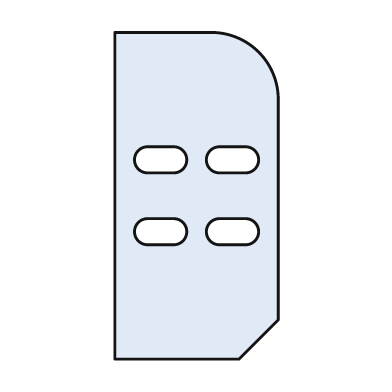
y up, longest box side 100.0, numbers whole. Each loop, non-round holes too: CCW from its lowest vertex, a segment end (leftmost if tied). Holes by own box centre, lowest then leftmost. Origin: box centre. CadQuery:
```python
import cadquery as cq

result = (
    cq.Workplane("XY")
    .moveTo(-25.0, -50.0)
    .lineTo(13.0, -50.0)
    .lineTo(25.0, -38.0)
    .lineTo(25.0, 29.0)
    .threePointArc((19.0, 44.0), (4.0, 50.0))
    .lineTo(-25.0, 50.0)
    .close()
    .moveTo(-15.0, -15.0)
    .lineTo(-7.0, -15.0)
    .threePointArc((-3.0, -11.0), (-7.0, -7.0))
    .lineTo(-15.0, -7.0)
    .threePointArc((-19.0, -11.0), (-15.0, -15.0))
    .close()
    .moveTo(7.0, -15.0)
    .lineTo(15.0, -15.0)
    .threePointArc((19.0, -11.0), (15.0, -7.0))
    .lineTo(7.0, -7.0)
    .threePointArc((3.0, -11.0), (7.0, -15.0))
    .close()
    .moveTo(-15.0, 7.0)
    .lineTo(-7.0, 7.0)
    .threePointArc((-3.0, 11.0), (-7.0, 15.0))
    .lineTo(-15.0, 15.0)
    .threePointArc((-19.0, 11.0), (-15.0, 7.0))
    .close()
    .moveTo(7.0, 7.0)
    .lineTo(15.0, 7.0)
    .threePointArc((19.0, 11.0), (15.0, 15.0))
    .lineTo(7.0, 15.0)
    .threePointArc((3.0, 11.0), (7.0, 7.0))
    .close()
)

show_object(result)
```